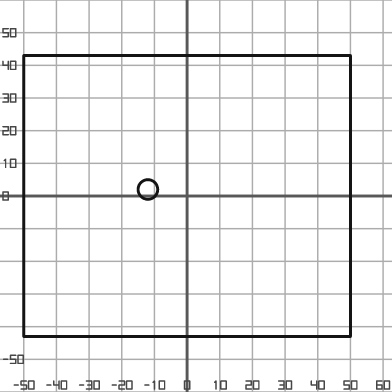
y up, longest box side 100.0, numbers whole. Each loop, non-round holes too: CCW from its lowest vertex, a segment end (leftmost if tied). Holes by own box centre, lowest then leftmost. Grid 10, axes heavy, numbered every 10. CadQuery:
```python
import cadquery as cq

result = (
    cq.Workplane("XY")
    .moveTo(-50.0, -43.0)
    .lineTo(50.0, -43.0)
    .lineTo(50.0, 43.0)
    .lineTo(-50.0, 43.0)
    .close()
    .moveTo(-12.0, 2.0)
    .circle(3.0)
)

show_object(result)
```